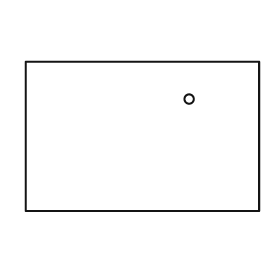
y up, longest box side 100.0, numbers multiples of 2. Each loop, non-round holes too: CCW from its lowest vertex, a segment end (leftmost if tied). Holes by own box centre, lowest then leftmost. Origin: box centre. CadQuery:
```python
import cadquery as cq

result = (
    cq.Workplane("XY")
    .moveTo(-50.0, -32.0)
    .lineTo(50.0, -32.0)
    .lineTo(50.0, 32.0)
    .lineTo(-50.0, 32.0)
    .close()
    .moveTo(20.0, 16.0)
    .circle(2.0)
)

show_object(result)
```